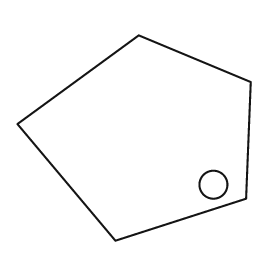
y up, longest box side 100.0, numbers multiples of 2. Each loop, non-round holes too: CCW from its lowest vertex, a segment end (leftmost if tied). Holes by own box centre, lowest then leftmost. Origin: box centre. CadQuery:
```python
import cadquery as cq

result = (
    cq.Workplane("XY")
    .moveTo(-8.0, -44.0)
    .lineTo(48.0, -26.0)
    .lineTo(50.0, 24.0)
    .lineTo(2.0, 44.0)
    .lineTo(-50.0, 6.0)
    .close()
    .moveTo(34.0, -20.0)
    .circle(6.0)
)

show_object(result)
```